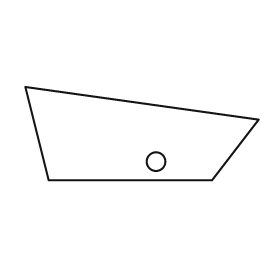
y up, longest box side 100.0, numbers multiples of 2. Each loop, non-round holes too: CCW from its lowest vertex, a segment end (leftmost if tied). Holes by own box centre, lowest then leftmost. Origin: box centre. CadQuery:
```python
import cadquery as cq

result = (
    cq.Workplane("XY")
    .moveTo(-40.0, -20.0)
    .lineTo(30.0, -20.0)
    .lineTo(50.0, 6.0)
    .lineTo(-50.0, 20.0)
    .close()
    .moveTo(6.0, -12.0)
    .circle(4.0)
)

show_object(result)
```